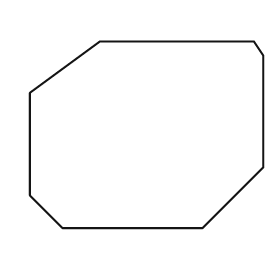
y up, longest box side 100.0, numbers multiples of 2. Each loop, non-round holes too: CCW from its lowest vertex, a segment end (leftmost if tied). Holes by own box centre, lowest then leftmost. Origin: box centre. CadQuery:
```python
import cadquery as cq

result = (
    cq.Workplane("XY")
    .moveTo(-36.0, -40.0)
    .lineTo(24.0, -40.0)
    .lineTo(50.0, -14.0)
    .lineTo(50.0, 34.0)
    .lineTo(46.0, 40.0)
    .lineTo(-20.0, 40.0)
    .lineTo(-50.0, 18.0)
    .lineTo(-50.0, -26.0)
    .close()
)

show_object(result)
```